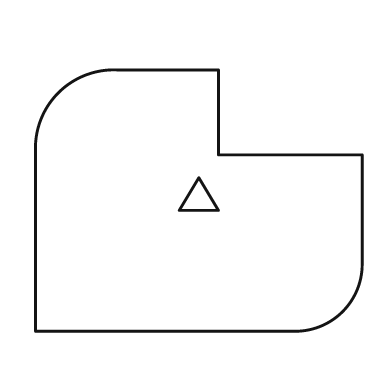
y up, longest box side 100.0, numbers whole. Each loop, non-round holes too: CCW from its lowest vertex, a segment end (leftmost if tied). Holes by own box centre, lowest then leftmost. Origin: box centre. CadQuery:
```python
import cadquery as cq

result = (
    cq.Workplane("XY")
    .moveTo(-50.0, -40.0)
    .lineTo(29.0, -40.0)
    .threePointArc((44.0, -34.0), (50.0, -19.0))
    .lineTo(50.0, 14.0)
    .lineTo(6.0, 14.0)
    .lineTo(6.0, 40.0)
    .lineTo(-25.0, 40.0)
    .threePointArc((-43.0, 33.0), (-50.0, 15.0))
    .close()
    .moveTo(-6.0, -3.0)
    .lineTo(6.0, -3.0)
    .lineTo(0.0, 7.0)
    .close()
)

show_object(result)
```